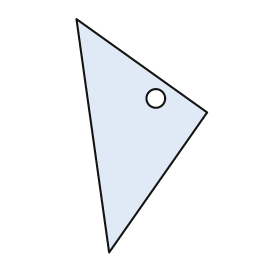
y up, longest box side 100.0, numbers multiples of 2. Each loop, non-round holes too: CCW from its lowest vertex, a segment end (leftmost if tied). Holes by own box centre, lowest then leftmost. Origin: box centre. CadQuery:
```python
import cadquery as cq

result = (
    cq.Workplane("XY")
    .moveTo(-14.0, -50.0)
    .lineTo(28.0, 10.0)
    .lineTo(-28.0, 50.0)
    .close()
    .moveTo(6.0, 16.0)
    .circle(4.0)
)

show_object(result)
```